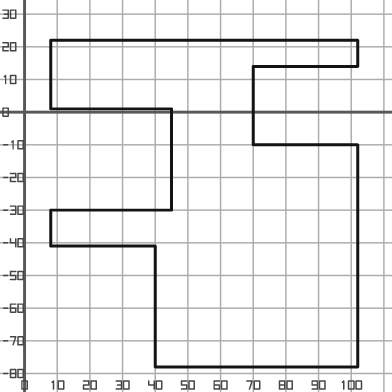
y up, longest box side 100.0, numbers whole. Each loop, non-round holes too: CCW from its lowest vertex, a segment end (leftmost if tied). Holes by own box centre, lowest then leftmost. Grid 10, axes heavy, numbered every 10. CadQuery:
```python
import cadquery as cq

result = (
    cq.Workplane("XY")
    .moveTo(40.0, -78.0)
    .lineTo(102.0, -78.0)
    .lineTo(102.0, -10.0)
    .lineTo(70.0, -10.0)
    .lineTo(70.0, 14.0)
    .lineTo(102.0, 14.0)
    .lineTo(102.0, 22.0)
    .lineTo(8.0, 22.0)
    .lineTo(8.0, 1.0)
    .lineTo(45.0, 1.0)
    .lineTo(45.0, -30.0)
    .lineTo(8.0, -30.0)
    .lineTo(8.0, -41.0)
    .lineTo(40.0, -41.0)
    .close()
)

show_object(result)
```